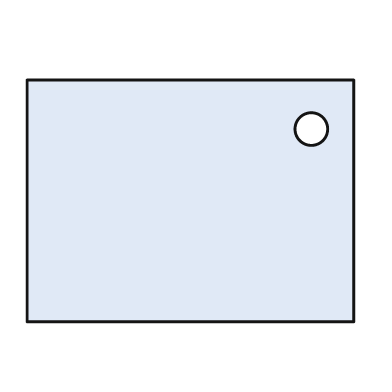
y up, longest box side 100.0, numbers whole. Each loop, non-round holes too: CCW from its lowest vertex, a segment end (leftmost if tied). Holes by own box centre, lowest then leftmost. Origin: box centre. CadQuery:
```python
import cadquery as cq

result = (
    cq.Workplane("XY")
    .moveTo(-50.0, -37.0)
    .lineTo(50.0, -37.0)
    .lineTo(50.0, 37.0)
    .lineTo(-50.0, 37.0)
    .close()
    .moveTo(37.0, 22.0)
    .circle(5.0)
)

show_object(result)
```